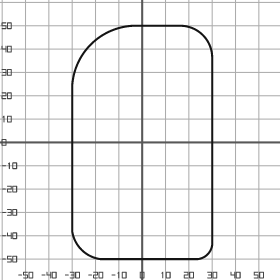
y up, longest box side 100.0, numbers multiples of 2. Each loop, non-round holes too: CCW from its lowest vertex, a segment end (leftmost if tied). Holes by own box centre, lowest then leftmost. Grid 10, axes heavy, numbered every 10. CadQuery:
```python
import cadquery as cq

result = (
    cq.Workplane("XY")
    .moveTo(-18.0, -50.0)
    .lineTo(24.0, -50.0)
    .threePointArc((28.0, -48.0), (30.0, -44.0))
    .lineTo(30.0, 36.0)
    .threePointArc((26.0, 46.0), (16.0, 50.0))
    .lineTo(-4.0, 50.0)
    .threePointArc((-22.0, 42.0), (-30.0, 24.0))
    .lineTo(-30.0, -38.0)
    .threePointArc((-26.0, -46.0), (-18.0, -50.0))
    .close()
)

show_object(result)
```